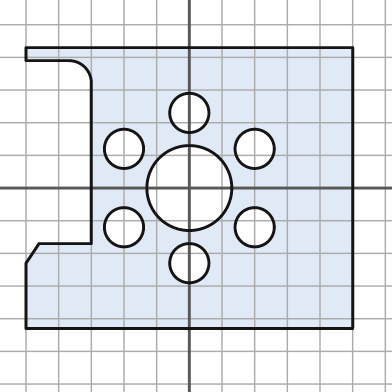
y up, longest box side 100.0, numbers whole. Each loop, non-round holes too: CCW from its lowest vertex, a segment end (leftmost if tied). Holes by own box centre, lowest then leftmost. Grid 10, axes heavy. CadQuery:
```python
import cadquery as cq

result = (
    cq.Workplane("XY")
    .moveTo(-50.0, -43.0)
    .lineTo(50.0, -43.0)
    .lineTo(50.0, 43.0)
    .lineTo(-50.0, 43.0)
    .lineTo(-50.0, 39.0)
    .lineTo(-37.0, 39.0)
    .threePointArc((-32.0, 37.0), (-30.0, 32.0))
    .lineTo(-30.0, -17.0)
    .lineTo(-46.0, -17.0)
    .lineTo(-50.0, -23.0)
    .close()
    .moveTo(0.0, -23.0)
    .circle(6.0)
    .moveTo(-20.0, -12.0)
    .circle(6.0)
    .moveTo(20.0, -12.0)
    .circle(6.0)
    .moveTo(0.0, 0.0)
    .circle(13.0)
    .moveTo(-20.0, 12.0)
    .circle(6.0)
    .moveTo(20.0, 12.0)
    .circle(6.0)
    .moveTo(0.0, 23.0)
    .circle(6.0)
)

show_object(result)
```